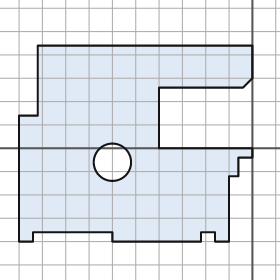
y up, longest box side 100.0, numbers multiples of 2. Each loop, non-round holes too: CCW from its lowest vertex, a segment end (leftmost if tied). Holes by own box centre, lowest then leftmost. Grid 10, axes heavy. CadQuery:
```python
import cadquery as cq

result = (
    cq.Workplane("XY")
    .moveTo(-100.0, -40.0)
    .lineTo(-94.0, -40.0)
    .lineTo(-94.0, -36.0)
    .lineTo(-60.0, -36.0)
    .lineTo(-60.0, -40.0)
    .lineTo(-22.0, -40.0)
    .lineTo(-22.0, -36.0)
    .lineTo(-16.0, -36.0)
    .lineTo(-16.0, -40.0)
    .lineTo(-10.0, -40.0)
    .lineTo(-10.0, -12.0)
    .lineTo(-6.0, -12.0)
    .lineTo(-6.0, -4.0)
    .lineTo(0.0, -4.0)
    .lineTo(0.0, 0.0)
    .lineTo(-40.0, 0.0)
    .lineTo(-40.0, 26.0)
    .lineTo(-4.0, 26.0)
    .lineTo(0.0, 30.0)
    .lineTo(0.0, 44.0)
    .lineTo(-92.0, 44.0)
    .lineTo(-92.0, 14.0)
    .lineTo(-100.0, 14.0)
    .close()
    .moveTo(-60.0, -6.0)
    .circle(8.0)
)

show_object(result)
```